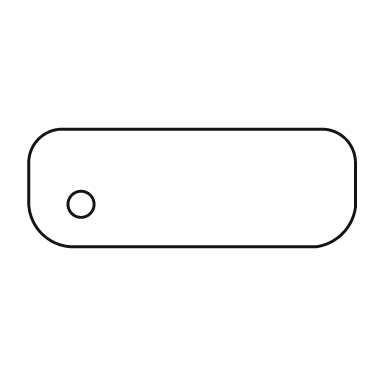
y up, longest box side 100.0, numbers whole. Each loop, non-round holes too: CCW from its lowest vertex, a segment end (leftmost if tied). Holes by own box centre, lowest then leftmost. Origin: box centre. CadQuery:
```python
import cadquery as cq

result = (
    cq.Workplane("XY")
    .moveTo(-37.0, -18.0)
    .lineTo(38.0, -18.0)
    .threePointArc((46.0, -14.0), (50.0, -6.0))
    .lineTo(50.0, 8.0)
    .threePointArc((47.0, 15.0), (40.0, 18.0))
    .lineTo(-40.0, 18.0)
    .threePointArc((-47.0, 15.0), (-50.0, 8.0))
    .lineTo(-50.0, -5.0)
    .threePointArc((-46.0, -14.0), (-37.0, -18.0))
    .close()
    .moveTo(-34.0, -5.0)
    .circle(4.0)
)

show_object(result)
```